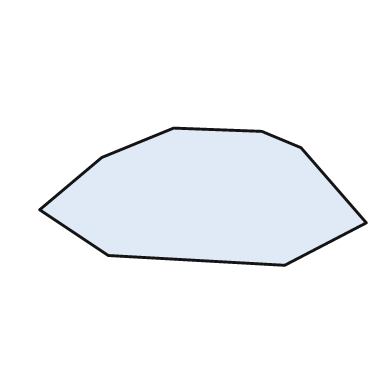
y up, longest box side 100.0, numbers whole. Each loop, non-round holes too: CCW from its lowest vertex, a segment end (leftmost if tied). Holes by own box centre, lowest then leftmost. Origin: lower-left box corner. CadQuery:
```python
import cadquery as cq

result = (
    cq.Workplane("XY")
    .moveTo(75.0, 0.0)
    .lineTo(100.0, 13.0)
    .lineTo(80.0, 36.0)
    .lineTo(68.0, 41.0)
    .lineTo(41.0, 42.0)
    .lineTo(19.0, 33.0)
    .lineTo(0.0, 17.0)
    .lineTo(21.0, 3.0)
    .close()
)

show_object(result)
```